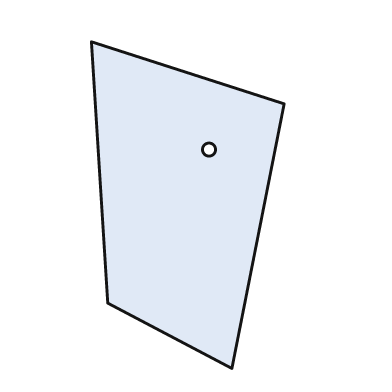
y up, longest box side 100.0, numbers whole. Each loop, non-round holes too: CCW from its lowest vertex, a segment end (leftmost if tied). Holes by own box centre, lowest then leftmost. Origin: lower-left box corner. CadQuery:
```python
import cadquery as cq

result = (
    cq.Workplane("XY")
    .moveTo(43.0, 0.0)
    .lineTo(59.0, 81.0)
    .lineTo(0.0, 100.0)
    .lineTo(5.0, 20.0)
    .close()
    .moveTo(36.0, 67.0)
    .circle(2.0)
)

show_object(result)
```